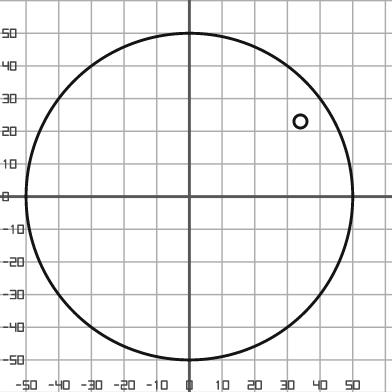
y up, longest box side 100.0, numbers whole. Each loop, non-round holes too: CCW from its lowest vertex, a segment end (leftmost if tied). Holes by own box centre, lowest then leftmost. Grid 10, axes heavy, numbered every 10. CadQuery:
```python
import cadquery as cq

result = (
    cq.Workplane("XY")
    .moveTo(0.0, 0.0)
    .circle(50.0)
    .moveTo(34.0, 23.0)
    .circle(2.0)
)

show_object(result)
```